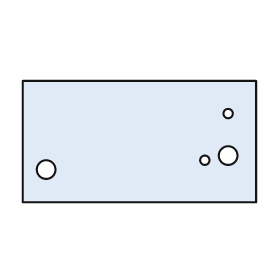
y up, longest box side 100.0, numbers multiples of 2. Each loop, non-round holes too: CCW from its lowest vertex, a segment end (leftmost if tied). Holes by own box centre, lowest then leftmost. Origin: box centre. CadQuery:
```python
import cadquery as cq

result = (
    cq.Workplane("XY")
    .moveTo(-50.0, -26.0)
    .lineTo(50.0, -26.0)
    .lineTo(50.0, 26.0)
    .lineTo(-50.0, 26.0)
    .close()
    .moveTo(-40.0, -12.0)
    .circle(4.0)
    .moveTo(28.0, -8.0)
    .circle(2.0)
    .moveTo(38.0, -6.0)
    .circle(4.0)
    .moveTo(38.0, 12.0)
    .circle(2.0)
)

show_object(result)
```